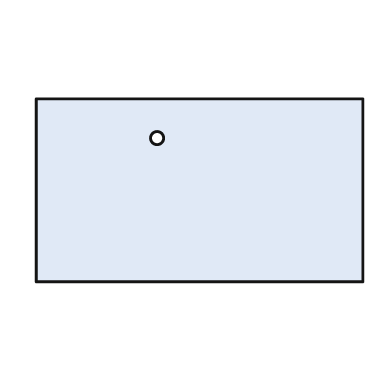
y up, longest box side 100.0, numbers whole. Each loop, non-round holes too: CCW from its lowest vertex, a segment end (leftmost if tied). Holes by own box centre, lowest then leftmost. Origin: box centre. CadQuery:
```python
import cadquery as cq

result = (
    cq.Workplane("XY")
    .moveTo(-50.0, -28.0)
    .lineTo(50.0, -28.0)
    .lineTo(50.0, 28.0)
    .lineTo(-50.0, 28.0)
    .close()
    .moveTo(-13.0, 16.0)
    .circle(2.0)
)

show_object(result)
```